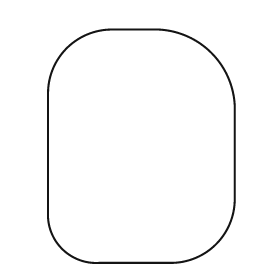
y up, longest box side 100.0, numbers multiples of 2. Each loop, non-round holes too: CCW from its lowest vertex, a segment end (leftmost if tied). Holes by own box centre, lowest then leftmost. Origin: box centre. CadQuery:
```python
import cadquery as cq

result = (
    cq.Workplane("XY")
    .moveTo(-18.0, -50.0)
    .lineTo(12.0, -50.0)
    .threePointArc((32.0, -42.0), (40.0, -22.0))
    .lineTo(40.0, 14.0)
    .threePointArc((30.0, 40.0), (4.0, 50.0))
    .lineTo(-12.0, 50.0)
    .threePointArc((-32.0, 42.0), (-40.0, 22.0))
    .lineTo(-40.0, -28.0)
    .threePointArc((-34.0, -44.0), (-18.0, -50.0))
    .close()
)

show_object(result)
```